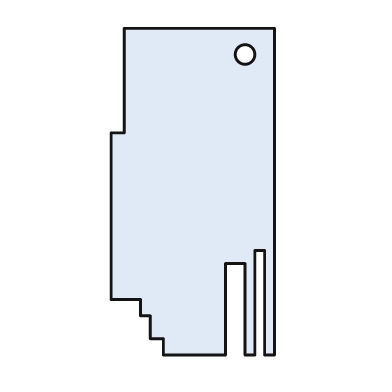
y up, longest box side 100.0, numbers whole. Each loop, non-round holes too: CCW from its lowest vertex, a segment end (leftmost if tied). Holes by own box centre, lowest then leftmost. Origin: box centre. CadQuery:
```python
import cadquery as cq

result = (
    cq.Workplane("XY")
    .moveTo(-9.0, -50.0)
    .lineTo(10.0, -50.0)
    .lineTo(10.0, -22.0)
    .lineTo(16.0, -22.0)
    .lineTo(16.0, -50.0)
    .lineTo(19.0, -50.0)
    .lineTo(19.0, -18.0)
    .lineTo(22.0, -18.0)
    .lineTo(22.0, -50.0)
    .lineTo(25.0, -50.0)
    .lineTo(25.0, 50.0)
    .lineTo(-21.0, 50.0)
    .lineTo(-21.0, 18.0)
    .lineTo(-25.0, 18.0)
    .lineTo(-25.0, -33.0)
    .lineTo(-16.0, -33.0)
    .lineTo(-16.0, -38.0)
    .lineTo(-13.0, -38.0)
    .lineTo(-13.0, -45.0)
    .lineTo(-9.0, -45.0)
    .close()
    .moveTo(16.0, 42.0)
    .circle(3.0)
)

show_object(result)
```